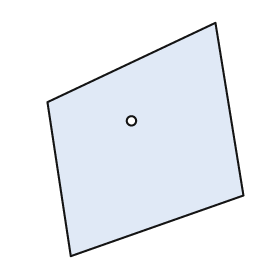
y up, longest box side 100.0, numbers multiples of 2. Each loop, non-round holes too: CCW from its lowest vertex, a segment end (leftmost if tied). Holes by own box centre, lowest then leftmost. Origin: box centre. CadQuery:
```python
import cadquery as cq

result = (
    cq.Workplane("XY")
    .moveTo(-32.0, -50.0)
    .lineTo(42.0, -24.0)
    .lineTo(30.0, 50.0)
    .lineTo(-42.0, 16.0)
    .close()
    .moveTo(-6.0, 8.0)
    .circle(2.0)
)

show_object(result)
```